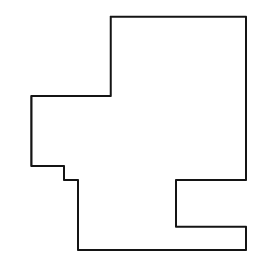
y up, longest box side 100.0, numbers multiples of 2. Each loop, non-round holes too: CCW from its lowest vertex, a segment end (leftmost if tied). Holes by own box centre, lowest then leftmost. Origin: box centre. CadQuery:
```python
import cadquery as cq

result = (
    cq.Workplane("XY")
    .moveTo(-26.0, -50.0)
    .lineTo(46.0, -50.0)
    .lineTo(46.0, -40.0)
    .lineTo(16.0, -40.0)
    .lineTo(16.0, -20.0)
    .lineTo(46.0, -20.0)
    .lineTo(46.0, 50.0)
    .lineTo(-12.0, 50.0)
    .lineTo(-12.0, 16.0)
    .lineTo(-46.0, 16.0)
    .lineTo(-46.0, -14.0)
    .lineTo(-32.0, -14.0)
    .lineTo(-32.0, -20.0)
    .lineTo(-26.0, -20.0)
    .close()
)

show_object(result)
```